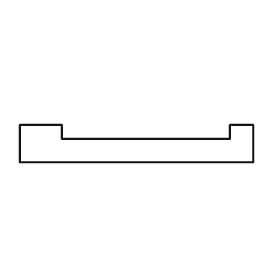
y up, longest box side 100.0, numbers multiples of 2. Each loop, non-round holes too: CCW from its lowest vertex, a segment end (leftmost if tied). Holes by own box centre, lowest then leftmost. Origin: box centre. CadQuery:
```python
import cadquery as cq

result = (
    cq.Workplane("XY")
    .moveTo(-50.0, -8.0)
    .lineTo(50.0, -8.0)
    .lineTo(50.0, 8.0)
    .lineTo(40.0, 8.0)
    .lineTo(40.0, 2.0)
    .lineTo(-32.0, 2.0)
    .lineTo(-32.0, 8.0)
    .lineTo(-50.0, 8.0)
    .close()
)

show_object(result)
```